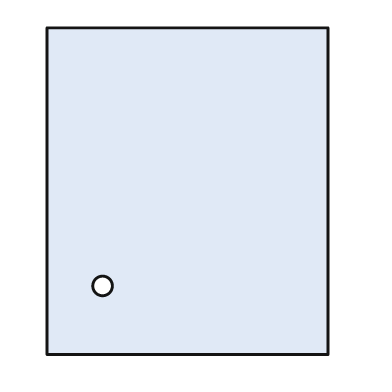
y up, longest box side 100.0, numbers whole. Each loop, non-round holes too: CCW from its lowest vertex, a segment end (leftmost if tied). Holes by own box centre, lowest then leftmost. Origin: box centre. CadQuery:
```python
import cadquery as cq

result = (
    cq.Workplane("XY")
    .moveTo(-43.0, -50.0)
    .lineTo(43.0, -50.0)
    .lineTo(43.0, 50.0)
    .lineTo(-43.0, 50.0)
    .close()
    .moveTo(-26.0, -29.0)
    .circle(3.0)
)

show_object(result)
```